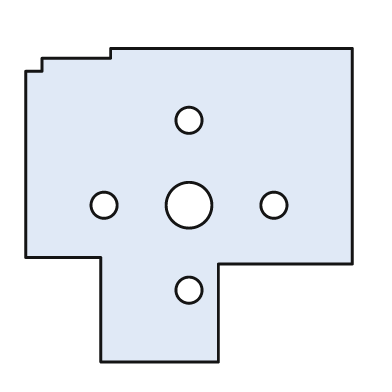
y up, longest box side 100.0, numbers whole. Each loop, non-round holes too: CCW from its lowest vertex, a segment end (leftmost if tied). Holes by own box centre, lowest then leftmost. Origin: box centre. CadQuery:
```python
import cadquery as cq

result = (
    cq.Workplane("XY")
    .moveTo(-27.0, -48.0)
    .lineTo(9.0, -48.0)
    .lineTo(9.0, -18.0)
    .lineTo(50.0, -18.0)
    .lineTo(50.0, 48.0)
    .lineTo(-24.0, 48.0)
    .lineTo(-24.0, 45.0)
    .lineTo(-45.0, 45.0)
    .lineTo(-45.0, 41.0)
    .lineTo(-50.0, 41.0)
    .lineTo(-50.0, -16.0)
    .lineTo(-27.0, -16.0)
    .close()
    .moveTo(0.0, -26.0)
    .circle(4.0)
    .moveTo(-26.0, 0.0)
    .circle(4.0)
    .moveTo(0.0, 0.0)
    .circle(7.0)
    .moveTo(26.0, 0.0)
    .circle(4.0)
    .moveTo(0.0, 26.0)
    .circle(4.0)
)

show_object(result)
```